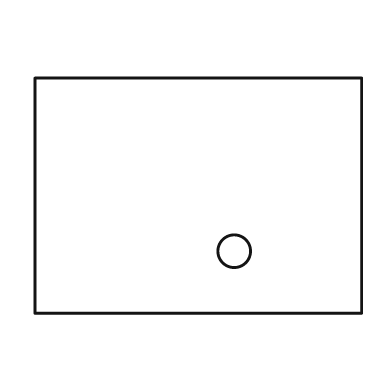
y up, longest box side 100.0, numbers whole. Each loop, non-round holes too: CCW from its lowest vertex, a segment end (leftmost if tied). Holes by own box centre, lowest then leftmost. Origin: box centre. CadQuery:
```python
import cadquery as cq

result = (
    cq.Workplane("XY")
    .moveTo(-50.0, -36.0)
    .lineTo(50.0, -36.0)
    .lineTo(50.0, 36.0)
    .lineTo(-50.0, 36.0)
    .close()
    .moveTo(11.0, -17.0)
    .circle(5.0)
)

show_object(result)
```